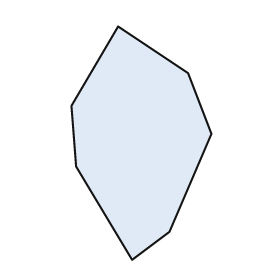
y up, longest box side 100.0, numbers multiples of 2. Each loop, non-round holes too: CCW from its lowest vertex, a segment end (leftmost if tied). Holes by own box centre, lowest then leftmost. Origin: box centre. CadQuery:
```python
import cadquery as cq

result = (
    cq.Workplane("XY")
    .moveTo(-4.0, -50.0)
    .lineTo(12.0, -38.0)
    .lineTo(30.0, 4.0)
    .lineTo(20.0, 30.0)
    .lineTo(-10.0, 50.0)
    .lineTo(-30.0, 16.0)
    .lineTo(-28.0, -10.0)
    .close()
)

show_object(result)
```